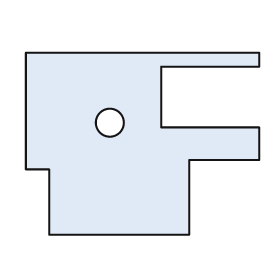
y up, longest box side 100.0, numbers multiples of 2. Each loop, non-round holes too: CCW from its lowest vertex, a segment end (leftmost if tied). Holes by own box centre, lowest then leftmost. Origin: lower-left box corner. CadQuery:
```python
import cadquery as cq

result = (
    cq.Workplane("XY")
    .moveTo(10.0, 0.0)
    .lineTo(70.0, 0.0)
    .lineTo(70.0, 32.0)
    .lineTo(100.0, 32.0)
    .lineTo(100.0, 46.0)
    .lineTo(58.0, 46.0)
    .lineTo(58.0, 72.0)
    .lineTo(100.0, 72.0)
    .lineTo(100.0, 78.0)
    .lineTo(0.0, 78.0)
    .lineTo(0.0, 28.0)
    .lineTo(10.0, 28.0)
    .close()
    .moveTo(36.0, 48.0)
    .circle(6.0)
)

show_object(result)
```